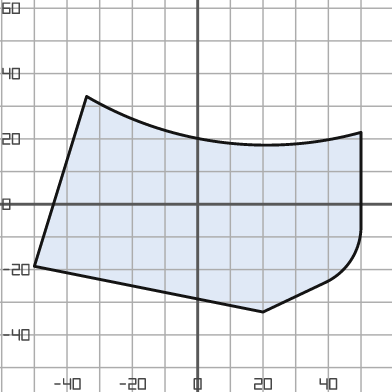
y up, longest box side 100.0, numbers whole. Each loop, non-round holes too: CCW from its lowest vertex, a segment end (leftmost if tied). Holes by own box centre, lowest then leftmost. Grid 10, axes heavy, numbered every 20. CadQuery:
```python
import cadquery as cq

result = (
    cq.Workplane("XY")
    .moveTo(20.0, -33.0)
    .lineTo(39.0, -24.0)
    .threePointArc((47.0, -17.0), (50.0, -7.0))
    .lineTo(50.0, 22.0)
    .threePointArc((7.0, 19.0), (-34.0, 33.0))
    .lineTo(-50.0, -19.0)
    .close()
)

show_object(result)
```